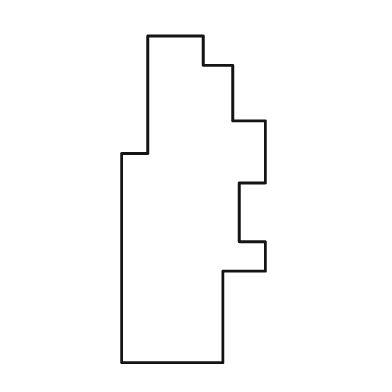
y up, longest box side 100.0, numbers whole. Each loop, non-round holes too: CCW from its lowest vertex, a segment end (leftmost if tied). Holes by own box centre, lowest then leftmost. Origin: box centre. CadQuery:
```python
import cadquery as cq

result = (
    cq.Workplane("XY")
    .moveTo(-22.0, -50.0)
    .lineTo(9.0, -50.0)
    .lineTo(9.0, -22.0)
    .lineTo(22.0, -22.0)
    .lineTo(22.0, -13.0)
    .lineTo(14.0, -13.0)
    .lineTo(14.0, 5.0)
    .lineTo(22.0, 5.0)
    .lineTo(22.0, 24.0)
    .lineTo(12.0, 24.0)
    .lineTo(12.0, 41.0)
    .lineTo(3.0, 41.0)
    .lineTo(3.0, 50.0)
    .lineTo(-14.0, 50.0)
    .lineTo(-14.0, 14.0)
    .lineTo(-22.0, 14.0)
    .close()
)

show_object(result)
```